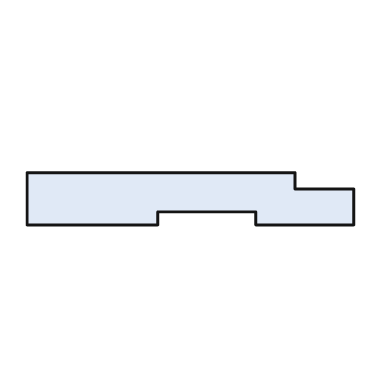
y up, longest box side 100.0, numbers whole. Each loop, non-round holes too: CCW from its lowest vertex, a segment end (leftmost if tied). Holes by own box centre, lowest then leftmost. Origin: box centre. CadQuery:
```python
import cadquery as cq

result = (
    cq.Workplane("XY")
    .moveTo(-50.0, -8.0)
    .lineTo(-10.0, -8.0)
    .lineTo(-10.0, -4.0)
    .lineTo(20.0, -4.0)
    .lineTo(20.0, -8.0)
    .lineTo(50.0, -8.0)
    .lineTo(50.0, 3.0)
    .lineTo(32.0, 3.0)
    .lineTo(32.0, 8.0)
    .lineTo(-50.0, 8.0)
    .close()
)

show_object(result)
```